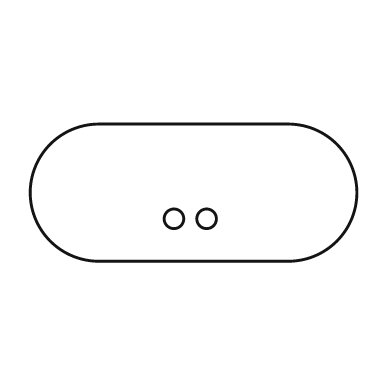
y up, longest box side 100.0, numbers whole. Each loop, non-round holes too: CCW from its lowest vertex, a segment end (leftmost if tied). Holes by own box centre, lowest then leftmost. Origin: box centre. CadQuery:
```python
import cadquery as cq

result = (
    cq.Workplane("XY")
    .moveTo(-29.0, -21.0)
    .lineTo(29.0, -21.0)
    .threePointArc((50.0, 0.0), (29.0, 21.0))
    .lineTo(-29.0, 21.0)
    .threePointArc((-50.0, 0.0), (-29.0, -21.0))
    .close()
    .moveTo(-6.0, -8.0)
    .circle(3.0)
    .moveTo(4.0, -8.0)
    .circle(3.0)
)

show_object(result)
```